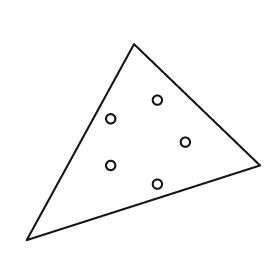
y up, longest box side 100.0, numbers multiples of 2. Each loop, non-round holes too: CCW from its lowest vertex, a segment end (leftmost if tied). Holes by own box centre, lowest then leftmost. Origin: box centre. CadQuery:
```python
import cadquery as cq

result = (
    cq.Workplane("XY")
    .moveTo(-50.0, -42.0)
    .lineTo(50.0, -10.0)
    .lineTo(-4.0, 42.0)
    .close()
    .moveTo(6.0, -18.0)
    .circle(2.0)
    .moveTo(-14.0, -10.0)
    .circle(2.0)
    .moveTo(18.0, 0.0)
    .circle(2.0)
    .moveTo(-14.0, 10.0)
    .circle(2.0)
    .moveTo(6.0, 18.0)
    .circle(2.0)
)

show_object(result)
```